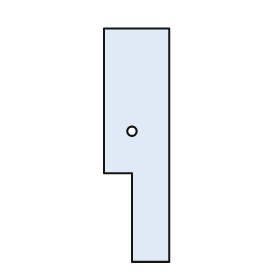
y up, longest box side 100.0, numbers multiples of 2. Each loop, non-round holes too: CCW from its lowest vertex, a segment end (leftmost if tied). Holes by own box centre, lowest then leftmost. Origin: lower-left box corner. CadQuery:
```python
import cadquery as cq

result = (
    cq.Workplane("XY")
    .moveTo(12.0, 0.0)
    .lineTo(28.0, 0.0)
    .lineTo(28.0, 100.0)
    .lineTo(0.0, 100.0)
    .lineTo(0.0, 38.0)
    .lineTo(12.0, 38.0)
    .close()
    .moveTo(12.0, 56.0)
    .circle(2.0)
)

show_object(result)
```